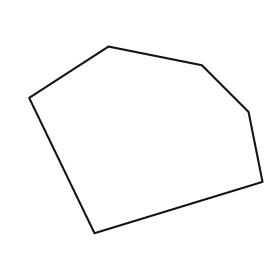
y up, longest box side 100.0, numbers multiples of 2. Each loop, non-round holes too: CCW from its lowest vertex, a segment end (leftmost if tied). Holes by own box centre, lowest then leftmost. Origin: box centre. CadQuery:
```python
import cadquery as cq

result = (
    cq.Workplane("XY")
    .moveTo(-22.0, -40.0)
    .lineTo(50.0, -18.0)
    .lineTo(44.0, 12.0)
    .lineTo(24.0, 32.0)
    .lineTo(-16.0, 40.0)
    .lineTo(-50.0, 18.0)
    .close()
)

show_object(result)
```